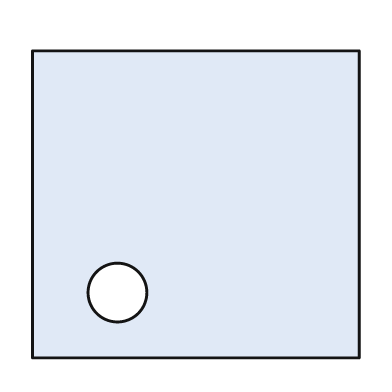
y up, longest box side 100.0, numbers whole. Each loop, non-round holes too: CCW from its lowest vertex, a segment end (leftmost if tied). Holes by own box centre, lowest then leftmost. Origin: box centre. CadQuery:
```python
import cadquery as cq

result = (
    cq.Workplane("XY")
    .moveTo(-50.0, -47.0)
    .lineTo(50.0, -47.0)
    .lineTo(50.0, 47.0)
    .lineTo(-50.0, 47.0)
    .close()
    .moveTo(-24.0, -27.0)
    .circle(9.0)
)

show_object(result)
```